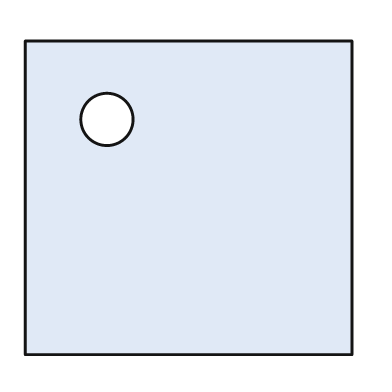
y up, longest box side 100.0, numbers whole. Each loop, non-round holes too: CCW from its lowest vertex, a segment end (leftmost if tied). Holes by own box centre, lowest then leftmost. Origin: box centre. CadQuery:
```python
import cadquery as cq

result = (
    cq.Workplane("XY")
    .moveTo(-50.0, -48.0)
    .lineTo(50.0, -48.0)
    .lineTo(50.0, 48.0)
    .lineTo(-50.0, 48.0)
    .close()
    .moveTo(-25.0, 24.0)
    .circle(8.0)
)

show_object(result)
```